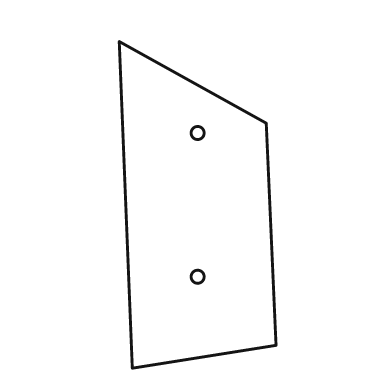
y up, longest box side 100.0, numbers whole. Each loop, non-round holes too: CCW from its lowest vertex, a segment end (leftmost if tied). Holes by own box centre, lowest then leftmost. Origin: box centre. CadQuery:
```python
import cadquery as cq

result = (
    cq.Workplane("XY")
    .moveTo(-20.0, -50.0)
    .lineTo(24.0, -43.0)
    .lineTo(21.0, 25.0)
    .lineTo(-24.0, 50.0)
    .close()
    .moveTo(0.0, -22.0)
    .circle(2.0)
    .moveTo(0.0, 22.0)
    .circle(2.0)
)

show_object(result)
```